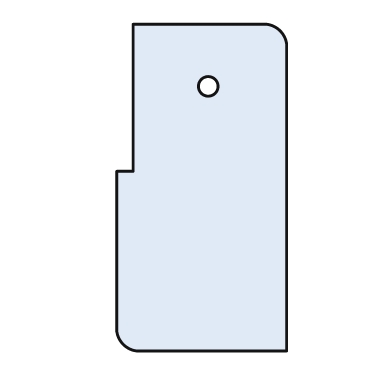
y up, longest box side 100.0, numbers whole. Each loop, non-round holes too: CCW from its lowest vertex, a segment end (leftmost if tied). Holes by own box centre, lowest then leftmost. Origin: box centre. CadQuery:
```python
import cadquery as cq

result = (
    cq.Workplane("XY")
    .moveTo(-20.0, -50.0)
    .lineTo(26.0, -50.0)
    .lineTo(26.0, 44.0)
    .threePointArc((24.0, 48.0), (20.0, 50.0))
    .lineTo(-21.0, 50.0)
    .lineTo(-21.0, 5.0)
    .lineTo(-26.0, 5.0)
    .lineTo(-26.0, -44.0)
    .threePointArc((-24.0, -48.0), (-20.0, -50.0))
    .close()
    .moveTo(2.0, 31.0)
    .circle(3.0)
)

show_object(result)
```